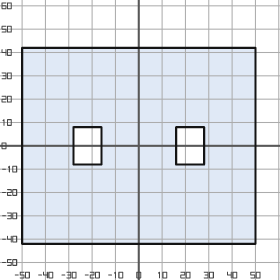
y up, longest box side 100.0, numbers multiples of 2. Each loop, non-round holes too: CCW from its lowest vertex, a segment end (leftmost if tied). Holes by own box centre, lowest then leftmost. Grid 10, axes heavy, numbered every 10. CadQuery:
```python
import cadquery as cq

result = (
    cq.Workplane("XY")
    .moveTo(-50.0, -42.0)
    .lineTo(50.0, -42.0)
    .lineTo(50.0, 42.0)
    .lineTo(-50.0, 42.0)
    .close()
    .moveTo(-28.0, -8.0)
    .lineTo(-16.0, -8.0)
    .lineTo(-16.0, 8.0)
    .lineTo(-28.0, 8.0)
    .close()
    .moveTo(16.0, -8.0)
    .lineTo(28.0, -8.0)
    .lineTo(28.0, 8.0)
    .lineTo(16.0, 8.0)
    .close()
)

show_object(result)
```